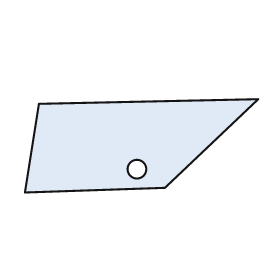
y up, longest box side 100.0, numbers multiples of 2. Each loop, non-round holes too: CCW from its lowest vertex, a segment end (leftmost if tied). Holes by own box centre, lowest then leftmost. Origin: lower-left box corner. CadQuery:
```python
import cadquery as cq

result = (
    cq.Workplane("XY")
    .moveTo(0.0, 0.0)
    .lineTo(60.0, 2.0)
    .lineTo(100.0, 40.0)
    .lineTo(6.0, 38.0)
    .close()
    .moveTo(48.0, 10.0)
    .circle(4.0)
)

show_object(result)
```